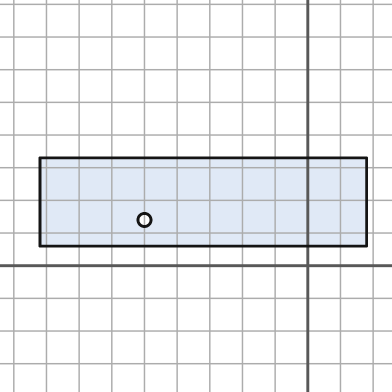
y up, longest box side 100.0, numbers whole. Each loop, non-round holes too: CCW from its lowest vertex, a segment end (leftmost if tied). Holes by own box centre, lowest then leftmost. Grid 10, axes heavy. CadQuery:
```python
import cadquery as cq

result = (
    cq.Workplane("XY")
    .moveTo(-82.0, 6.0)
    .lineTo(18.0, 6.0)
    .lineTo(18.0, 33.0)
    .lineTo(-82.0, 33.0)
    .close()
    .moveTo(-50.0, 14.0)
    .circle(2.0)
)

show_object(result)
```